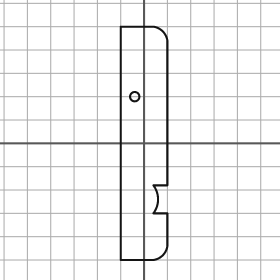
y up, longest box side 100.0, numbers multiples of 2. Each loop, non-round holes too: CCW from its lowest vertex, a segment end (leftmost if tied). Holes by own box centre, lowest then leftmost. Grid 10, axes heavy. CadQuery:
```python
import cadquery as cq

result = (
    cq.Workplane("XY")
    .moveTo(-10.0, -50.0)
    .lineTo(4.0, -50.0)
    .threePointArc((8.0, -48.0), (10.0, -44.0))
    .lineTo(10.0, -30.0)
    .lineTo(4.0, -30.0)
    .threePointArc((6.0, -24.0), (4.0, -18.0))
    .lineTo(10.0, -18.0)
    .lineTo(10.0, 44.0)
    .threePointArc((8.0, 48.0), (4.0, 50.0))
    .lineTo(-10.0, 50.0)
    .close()
    .moveTo(-4.0, 20.0)
    .circle(2.0)
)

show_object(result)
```